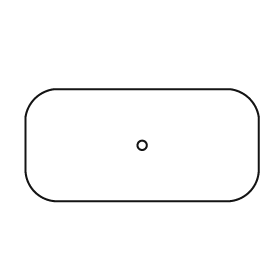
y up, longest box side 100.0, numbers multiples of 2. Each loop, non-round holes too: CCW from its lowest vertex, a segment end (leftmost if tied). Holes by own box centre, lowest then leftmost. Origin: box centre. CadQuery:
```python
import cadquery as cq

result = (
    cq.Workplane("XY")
    .moveTo(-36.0, -24.0)
    .lineTo(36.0, -24.0)
    .threePointArc((46.0, -20.0), (50.0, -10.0))
    .lineTo(50.0, 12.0)
    .threePointArc((46.0, 20.0), (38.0, 24.0))
    .lineTo(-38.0, 24.0)
    .threePointArc((-46.0, 20.0), (-50.0, 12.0))
    .lineTo(-50.0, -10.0)
    .threePointArc((-46.0, -20.0), (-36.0, -24.0))
    .close()
    .moveTo(0.0, 0.0)
    .circle(2.0)
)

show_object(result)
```